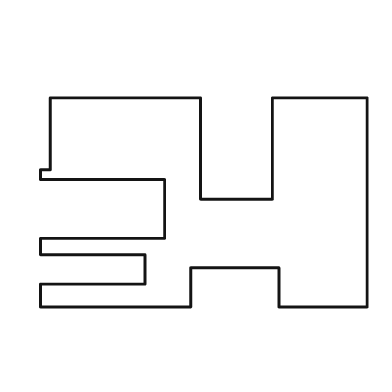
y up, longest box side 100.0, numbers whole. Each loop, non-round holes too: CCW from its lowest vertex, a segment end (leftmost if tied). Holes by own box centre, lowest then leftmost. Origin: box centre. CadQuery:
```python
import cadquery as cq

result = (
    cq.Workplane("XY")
    .moveTo(-50.0, -32.0)
    .lineTo(-4.0, -32.0)
    .lineTo(-4.0, -20.0)
    .lineTo(23.0, -20.0)
    .lineTo(23.0, -32.0)
    .lineTo(50.0, -32.0)
    .lineTo(50.0, 32.0)
    .lineTo(21.0, 32.0)
    .lineTo(21.0, 1.0)
    .lineTo(-1.0, 1.0)
    .lineTo(-1.0, 32.0)
    .lineTo(-47.0, 32.0)
    .lineTo(-47.0, 10.0)
    .lineTo(-50.0, 10.0)
    .lineTo(-50.0, 7.0)
    .lineTo(-12.0, 7.0)
    .lineTo(-12.0, -11.0)
    .lineTo(-50.0, -11.0)
    .lineTo(-50.0, -16.0)
    .lineTo(-18.0, -16.0)
    .lineTo(-18.0, -25.0)
    .lineTo(-50.0, -25.0)
    .close()
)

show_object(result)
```